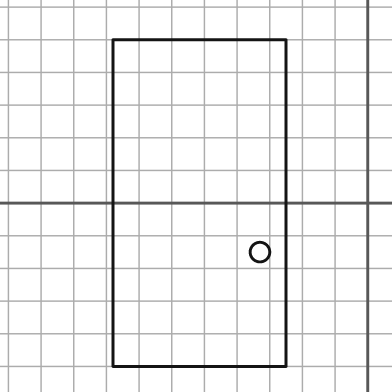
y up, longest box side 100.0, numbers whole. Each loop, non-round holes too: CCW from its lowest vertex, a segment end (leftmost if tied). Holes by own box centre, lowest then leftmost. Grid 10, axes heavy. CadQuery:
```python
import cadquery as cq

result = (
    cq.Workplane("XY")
    .moveTo(-78.0, -50.0)
    .lineTo(-25.0, -50.0)
    .lineTo(-25.0, 50.0)
    .lineTo(-78.0, 50.0)
    .close()
    .moveTo(-33.0, -15.0)
    .circle(3.0)
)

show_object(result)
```